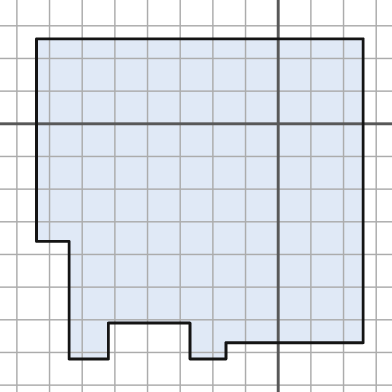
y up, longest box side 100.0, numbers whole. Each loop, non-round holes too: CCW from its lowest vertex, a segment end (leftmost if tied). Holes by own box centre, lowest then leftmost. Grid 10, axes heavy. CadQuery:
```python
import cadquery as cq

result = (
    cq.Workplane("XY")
    .moveTo(-64.0, -72.0)
    .lineTo(-52.0, -72.0)
    .lineTo(-52.0, -61.0)
    .lineTo(-27.0, -61.0)
    .lineTo(-27.0, -72.0)
    .lineTo(-16.0, -72.0)
    .lineTo(-16.0, -67.0)
    .lineTo(26.0, -67.0)
    .lineTo(26.0, 26.0)
    .lineTo(-74.0, 26.0)
    .lineTo(-74.0, -36.0)
    .lineTo(-64.0, -36.0)
    .close()
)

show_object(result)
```